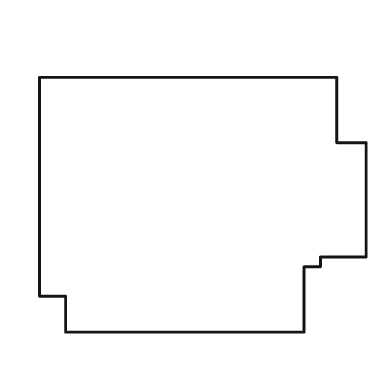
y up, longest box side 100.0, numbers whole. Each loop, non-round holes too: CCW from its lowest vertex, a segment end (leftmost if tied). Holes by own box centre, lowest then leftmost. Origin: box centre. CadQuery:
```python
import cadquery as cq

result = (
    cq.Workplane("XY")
    .moveTo(-42.0, -39.0)
    .lineTo(31.0, -39.0)
    .lineTo(31.0, -19.0)
    .lineTo(36.0, -19.0)
    .lineTo(36.0, -16.0)
    .lineTo(50.0, -16.0)
    .lineTo(50.0, 19.0)
    .lineTo(41.0, 19.0)
    .lineTo(41.0, 39.0)
    .lineTo(-50.0, 39.0)
    .lineTo(-50.0, -28.0)
    .lineTo(-42.0, -28.0)
    .close()
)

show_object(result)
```